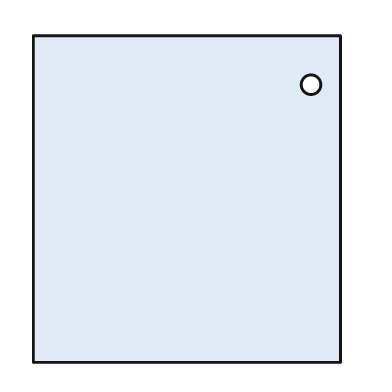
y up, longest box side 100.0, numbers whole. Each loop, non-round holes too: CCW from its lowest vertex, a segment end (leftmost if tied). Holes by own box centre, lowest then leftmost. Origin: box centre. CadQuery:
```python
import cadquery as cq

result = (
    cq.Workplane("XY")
    .moveTo(-47.0, -50.0)
    .lineTo(47.0, -50.0)
    .lineTo(47.0, 50.0)
    .lineTo(-47.0, 50.0)
    .close()
    .moveTo(38.0, 35.0)
    .circle(3.0)
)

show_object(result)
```